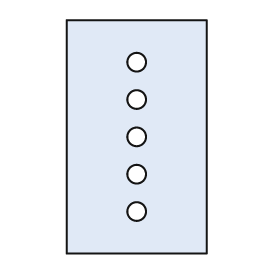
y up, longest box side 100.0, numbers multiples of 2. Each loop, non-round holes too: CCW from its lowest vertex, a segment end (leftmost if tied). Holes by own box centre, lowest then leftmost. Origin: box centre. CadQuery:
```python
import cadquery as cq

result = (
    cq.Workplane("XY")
    .moveTo(-30.0, -50.0)
    .lineTo(30.0, -50.0)
    .lineTo(30.0, 50.0)
    .lineTo(-30.0, 50.0)
    .close()
    .moveTo(0.0, -32.0)
    .circle(4.0)
    .moveTo(0.0, -16.0)
    .circle(4.0)
    .moveTo(0.0, 0.0)
    .circle(4.0)
    .moveTo(0.0, 16.0)
    .circle(4.0)
    .moveTo(0.0, 32.0)
    .circle(4.0)
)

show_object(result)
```